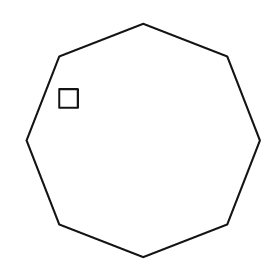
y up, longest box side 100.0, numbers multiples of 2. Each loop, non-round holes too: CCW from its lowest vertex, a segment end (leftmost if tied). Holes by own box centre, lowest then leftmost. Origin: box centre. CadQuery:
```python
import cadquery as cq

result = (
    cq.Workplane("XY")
    .moveTo(0.0, -50.0)
    .lineTo(36.0, -36.0)
    .lineTo(50.0, 0.0)
    .lineTo(36.0, 36.0)
    .lineTo(0.0, 50.0)
    .lineTo(-36.0, 36.0)
    .lineTo(-50.0, 0.0)
    .lineTo(-36.0, -36.0)
    .close()
    .moveTo(-36.0, 14.0)
    .lineTo(-28.0, 14.0)
    .lineTo(-28.0, 22.0)
    .lineTo(-36.0, 22.0)
    .close()
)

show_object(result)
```